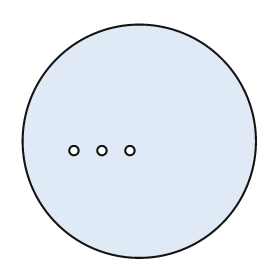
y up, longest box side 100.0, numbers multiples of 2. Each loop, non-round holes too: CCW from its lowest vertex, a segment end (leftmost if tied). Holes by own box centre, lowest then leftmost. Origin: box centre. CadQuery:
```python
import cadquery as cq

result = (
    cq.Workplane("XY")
    .moveTo(0.0, 0.0)
    .circle(50.0)
    .moveTo(-28.0, -4.0)
    .circle(2.0)
    .moveTo(-16.0, -4.0)
    .circle(2.0)
    .moveTo(-4.0, -4.0)
    .circle(2.0)
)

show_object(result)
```